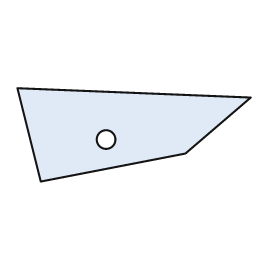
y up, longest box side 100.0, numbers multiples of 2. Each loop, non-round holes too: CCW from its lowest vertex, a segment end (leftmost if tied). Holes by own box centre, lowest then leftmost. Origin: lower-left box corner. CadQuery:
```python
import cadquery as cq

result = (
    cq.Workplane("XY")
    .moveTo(10.0, 0.0)
    .lineTo(72.0, 12.0)
    .lineTo(100.0, 36.0)
    .lineTo(0.0, 40.0)
    .close()
    .moveTo(38.0, 18.0)
    .circle(4.0)
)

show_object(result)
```